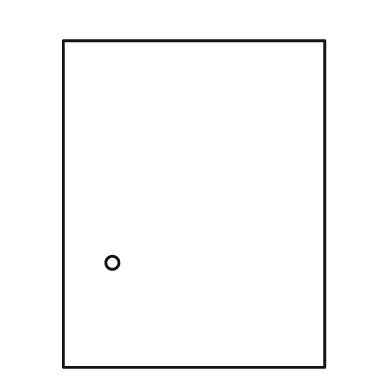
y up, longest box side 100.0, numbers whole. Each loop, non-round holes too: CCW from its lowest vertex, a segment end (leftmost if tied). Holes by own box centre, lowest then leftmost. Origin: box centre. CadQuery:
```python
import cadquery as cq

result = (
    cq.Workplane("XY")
    .moveTo(-40.0, -50.0)
    .lineTo(40.0, -50.0)
    .lineTo(40.0, 50.0)
    .lineTo(-40.0, 50.0)
    .close()
    .moveTo(-25.0, -18.0)
    .circle(2.0)
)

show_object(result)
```